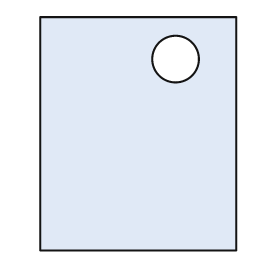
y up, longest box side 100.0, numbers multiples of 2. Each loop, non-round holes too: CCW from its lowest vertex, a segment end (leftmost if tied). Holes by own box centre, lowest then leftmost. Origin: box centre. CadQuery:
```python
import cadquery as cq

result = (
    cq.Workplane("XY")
    .moveTo(-42.0, -50.0)
    .lineTo(42.0, -50.0)
    .lineTo(42.0, 50.0)
    .lineTo(-42.0, 50.0)
    .close()
    .moveTo(16.0, 32.0)
    .circle(10.0)
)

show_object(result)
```